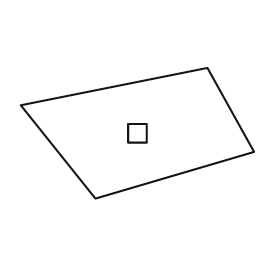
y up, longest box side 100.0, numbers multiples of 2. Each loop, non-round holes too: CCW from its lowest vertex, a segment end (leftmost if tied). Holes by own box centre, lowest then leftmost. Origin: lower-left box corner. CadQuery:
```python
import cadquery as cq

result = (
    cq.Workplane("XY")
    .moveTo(32.0, 0.0)
    .lineTo(100.0, 20.0)
    .lineTo(80.0, 56.0)
    .lineTo(0.0, 40.0)
    .close()
    .moveTo(46.0, 24.0)
    .lineTo(54.0, 24.0)
    .lineTo(54.0, 32.0)
    .lineTo(46.0, 32.0)
    .close()
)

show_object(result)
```